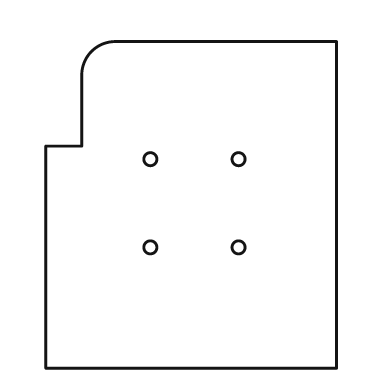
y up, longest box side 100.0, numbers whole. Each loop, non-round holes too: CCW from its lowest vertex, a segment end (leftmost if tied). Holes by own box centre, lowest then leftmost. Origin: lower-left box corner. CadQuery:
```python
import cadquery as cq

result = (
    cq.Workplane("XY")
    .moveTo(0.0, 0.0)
    .lineTo(89.0, 0.0)
    .lineTo(89.0, 100.0)
    .lineTo(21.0, 100.0)
    .threePointArc((14.0, 97.0), (11.0, 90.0))
    .lineTo(11.0, 68.0)
    .lineTo(0.0, 68.0)
    .close()
    .moveTo(32.0, 37.0)
    .circle(2.0)
    .moveTo(59.0, 37.0)
    .circle(2.0)
    .moveTo(32.0, 64.0)
    .circle(2.0)
    .moveTo(59.0, 64.0)
    .circle(2.0)
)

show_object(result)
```